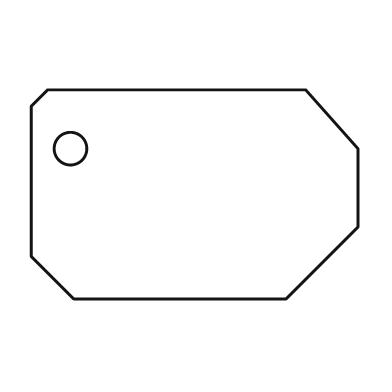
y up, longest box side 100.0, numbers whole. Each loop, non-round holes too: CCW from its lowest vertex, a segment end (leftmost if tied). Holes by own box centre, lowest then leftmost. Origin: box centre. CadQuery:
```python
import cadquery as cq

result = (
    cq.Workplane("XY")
    .moveTo(-37.0, -32.0)
    .lineTo(28.0, -32.0)
    .lineTo(50.0, -10.0)
    .lineTo(50.0, 14.0)
    .lineTo(34.0, 32.0)
    .lineTo(-45.0, 32.0)
    .lineTo(-50.0, 27.0)
    .lineTo(-50.0, -19.0)
    .close()
    .moveTo(-38.0, 14.0)
    .circle(5.0)
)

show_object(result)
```